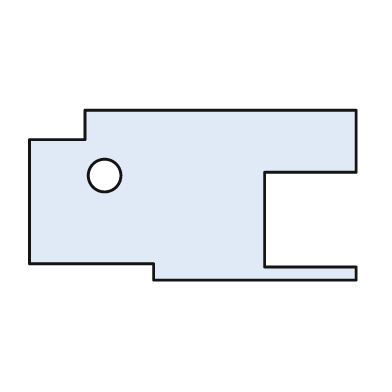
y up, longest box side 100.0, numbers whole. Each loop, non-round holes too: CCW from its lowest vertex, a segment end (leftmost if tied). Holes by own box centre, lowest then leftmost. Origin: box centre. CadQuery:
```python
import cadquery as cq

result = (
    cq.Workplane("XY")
    .moveTo(-12.0, -26.0)
    .lineTo(50.0, -26.0)
    .lineTo(50.0, -22.0)
    .lineTo(22.0, -22.0)
    .lineTo(22.0, 7.0)
    .lineTo(50.0, 7.0)
    .lineTo(50.0, 26.0)
    .lineTo(-33.0, 26.0)
    .lineTo(-33.0, 17.0)
    .lineTo(-50.0, 17.0)
    .lineTo(-50.0, -21.0)
    .lineTo(-12.0, -21.0)
    .close()
    .moveTo(-27.0, 6.0)
    .circle(5.0)
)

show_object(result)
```